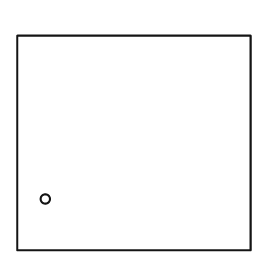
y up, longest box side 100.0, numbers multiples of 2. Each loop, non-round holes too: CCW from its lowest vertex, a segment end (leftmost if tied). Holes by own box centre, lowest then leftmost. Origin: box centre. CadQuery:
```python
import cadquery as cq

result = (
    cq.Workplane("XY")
    .moveTo(-50.0, -46.0)
    .lineTo(50.0, -46.0)
    .lineTo(50.0, 46.0)
    .lineTo(-50.0, 46.0)
    .close()
    .moveTo(-38.0, -24.0)
    .circle(2.0)
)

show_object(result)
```